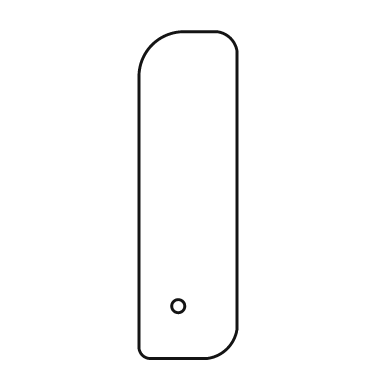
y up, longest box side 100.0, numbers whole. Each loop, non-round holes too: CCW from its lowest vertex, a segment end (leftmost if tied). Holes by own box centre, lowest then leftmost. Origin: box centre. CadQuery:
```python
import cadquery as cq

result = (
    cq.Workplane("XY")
    .moveTo(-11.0, -50.0)
    .lineTo(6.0, -50.0)
    .threePointArc((12.0, -47.0), (15.0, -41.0))
    .lineTo(15.0, 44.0)
    .threePointArc((13.0, 48.0), (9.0, 50.0))
    .lineTo(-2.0, 50.0)
    .threePointArc((-11.0, 46.0), (-15.0, 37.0))
    .lineTo(-15.0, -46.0)
    .threePointArc((-14.0, -49.0), (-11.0, -50.0))
    .close()
    .moveTo(-3.0, -34.0)
    .circle(2.0)
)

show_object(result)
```